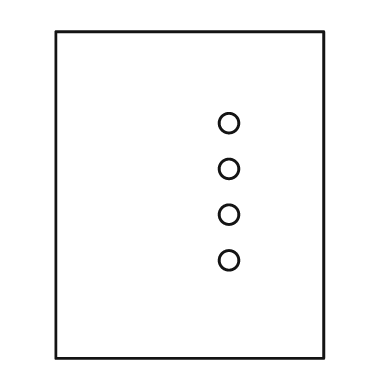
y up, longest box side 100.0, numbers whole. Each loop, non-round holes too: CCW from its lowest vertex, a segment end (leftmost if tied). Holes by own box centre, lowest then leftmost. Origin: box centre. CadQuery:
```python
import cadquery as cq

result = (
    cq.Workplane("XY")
    .moveTo(-41.0, -50.0)
    .lineTo(41.0, -50.0)
    .lineTo(41.0, 50.0)
    .lineTo(-41.0, 50.0)
    .close()
    .moveTo(12.0, -20.0)
    .circle(3.0)
    .moveTo(12.0, -6.0)
    .circle(3.0)
    .moveTo(12.0, 8.0)
    .circle(3.0)
    .moveTo(12.0, 22.0)
    .circle(3.0)
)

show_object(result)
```